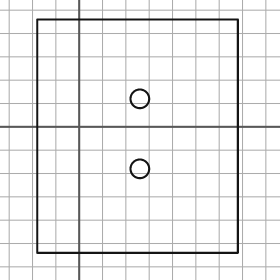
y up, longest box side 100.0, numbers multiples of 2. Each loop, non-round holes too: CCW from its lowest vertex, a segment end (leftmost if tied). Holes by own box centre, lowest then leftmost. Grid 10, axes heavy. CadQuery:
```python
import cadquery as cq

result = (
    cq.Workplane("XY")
    .moveTo(-18.0, -54.0)
    .lineTo(68.0, -54.0)
    .lineTo(68.0, 46.0)
    .lineTo(-18.0, 46.0)
    .close()
    .moveTo(26.0, -18.0)
    .circle(4.0)
    .moveTo(26.0, 12.0)
    .circle(4.0)
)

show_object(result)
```